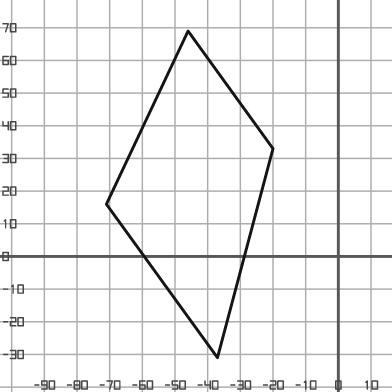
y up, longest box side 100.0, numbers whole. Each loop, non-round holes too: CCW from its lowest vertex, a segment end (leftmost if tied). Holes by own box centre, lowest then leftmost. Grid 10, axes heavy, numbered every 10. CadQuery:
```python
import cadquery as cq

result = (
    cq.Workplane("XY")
    .moveTo(-37.0, -31.0)
    .lineTo(-20.0, 33.0)
    .lineTo(-46.0, 69.0)
    .lineTo(-71.0, 16.0)
    .close()
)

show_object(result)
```